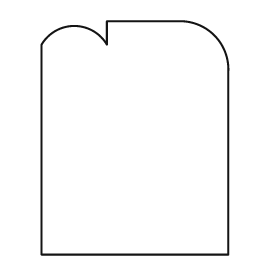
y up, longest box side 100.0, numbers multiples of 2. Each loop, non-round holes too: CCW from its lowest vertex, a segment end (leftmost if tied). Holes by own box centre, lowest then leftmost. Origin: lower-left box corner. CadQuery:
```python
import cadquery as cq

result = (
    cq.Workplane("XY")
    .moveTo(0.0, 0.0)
    .lineTo(80.0, 0.0)
    .lineTo(80.0, 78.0)
    .threePointArc((74.0, 94.0), (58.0, 100.0))
    .lineTo(28.0, 100.0)
    .lineTo(28.0, 90.0)
    .threePointArc((14.0, 98.0), (0.0, 90.0))
    .close()
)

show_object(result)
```